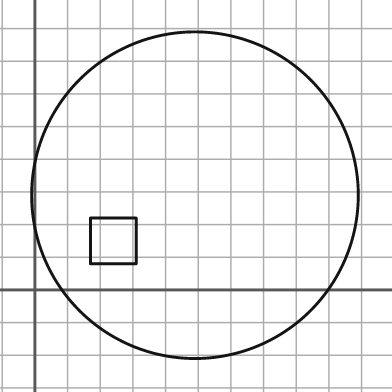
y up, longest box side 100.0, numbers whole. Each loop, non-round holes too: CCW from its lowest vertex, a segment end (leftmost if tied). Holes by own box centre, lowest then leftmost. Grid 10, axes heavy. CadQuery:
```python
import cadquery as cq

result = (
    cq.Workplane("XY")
    .moveTo(49.0, 29.0)
    .circle(50.0)
    .moveTo(17.0, 8.0)
    .lineTo(31.0, 8.0)
    .lineTo(31.0, 22.0)
    .lineTo(17.0, 22.0)
    .close()
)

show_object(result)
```